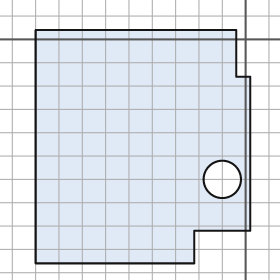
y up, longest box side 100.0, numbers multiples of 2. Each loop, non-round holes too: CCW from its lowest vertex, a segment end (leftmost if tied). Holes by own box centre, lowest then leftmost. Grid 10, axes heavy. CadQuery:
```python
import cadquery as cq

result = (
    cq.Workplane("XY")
    .moveTo(-90.0, -96.0)
    .lineTo(-22.0, -96.0)
    .lineTo(-22.0, -82.0)
    .lineTo(2.0, -82.0)
    .lineTo(2.0, -16.0)
    .lineTo(-4.0, -16.0)
    .lineTo(-4.0, 4.0)
    .lineTo(-90.0, 4.0)
    .close()
    .moveTo(-10.0, -60.0)
    .circle(8.0)
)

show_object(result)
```